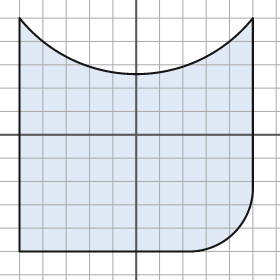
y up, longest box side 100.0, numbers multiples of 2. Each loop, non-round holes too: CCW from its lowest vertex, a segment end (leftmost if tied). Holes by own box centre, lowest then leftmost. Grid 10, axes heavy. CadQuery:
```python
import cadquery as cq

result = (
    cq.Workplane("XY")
    .moveTo(-50.0, -50.0)
    .lineTo(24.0, -50.0)
    .threePointArc((42.0, -42.0), (50.0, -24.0))
    .lineTo(50.0, 50.0)
    .threePointArc((0.0, 26.0), (-50.0, 50.0))
    .close()
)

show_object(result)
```